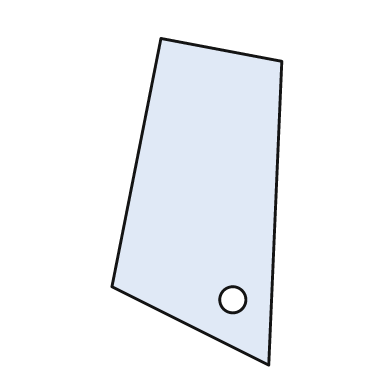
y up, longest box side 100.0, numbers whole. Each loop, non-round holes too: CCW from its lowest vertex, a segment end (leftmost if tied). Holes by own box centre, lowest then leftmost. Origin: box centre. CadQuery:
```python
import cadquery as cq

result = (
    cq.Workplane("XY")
    .moveTo(22.0, -50.0)
    .lineTo(26.0, 43.0)
    .lineTo(-11.0, 50.0)
    .lineTo(-26.0, -26.0)
    .close()
    .moveTo(11.0, -30.0)
    .circle(4.0)
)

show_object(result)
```